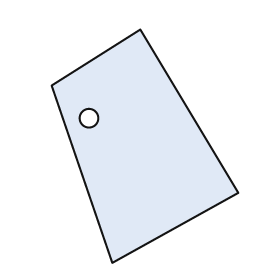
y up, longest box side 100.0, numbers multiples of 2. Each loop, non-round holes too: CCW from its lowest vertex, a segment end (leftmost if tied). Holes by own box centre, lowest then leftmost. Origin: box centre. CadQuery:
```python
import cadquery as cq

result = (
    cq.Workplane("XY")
    .moveTo(-14.0, -50.0)
    .lineTo(40.0, -20.0)
    .lineTo(-2.0, 50.0)
    .lineTo(-40.0, 26.0)
    .close()
    .moveTo(-24.0, 12.0)
    .circle(4.0)
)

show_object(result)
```